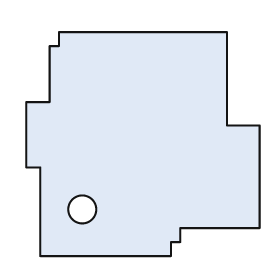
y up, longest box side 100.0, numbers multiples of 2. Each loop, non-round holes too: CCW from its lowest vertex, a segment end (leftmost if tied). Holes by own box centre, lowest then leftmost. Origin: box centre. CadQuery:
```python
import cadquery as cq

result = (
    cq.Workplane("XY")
    .moveTo(-44.0, -48.0)
    .lineTo(12.0, -48.0)
    .lineTo(12.0, -42.0)
    .lineTo(16.0, -42.0)
    .lineTo(16.0, -36.0)
    .lineTo(50.0, -36.0)
    .lineTo(50.0, 8.0)
    .lineTo(36.0, 8.0)
    .lineTo(36.0, 48.0)
    .lineTo(-36.0, 48.0)
    .lineTo(-36.0, 42.0)
    .lineTo(-40.0, 42.0)
    .lineTo(-40.0, 18.0)
    .lineTo(-50.0, 18.0)
    .lineTo(-50.0, -10.0)
    .lineTo(-44.0, -10.0)
    .close()
    .moveTo(-26.0, -28.0)
    .circle(6.0)
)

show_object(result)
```